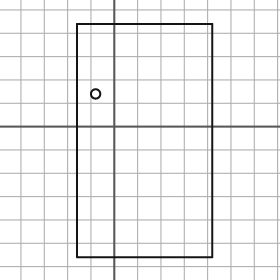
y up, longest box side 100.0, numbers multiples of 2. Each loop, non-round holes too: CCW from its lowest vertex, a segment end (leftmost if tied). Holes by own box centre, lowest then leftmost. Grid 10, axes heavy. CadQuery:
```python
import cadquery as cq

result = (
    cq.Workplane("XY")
    .moveTo(-16.0, -56.0)
    .lineTo(42.0, -56.0)
    .lineTo(42.0, 44.0)
    .lineTo(-16.0, 44.0)
    .close()
    .moveTo(-8.0, 14.0)
    .circle(2.0)
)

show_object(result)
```